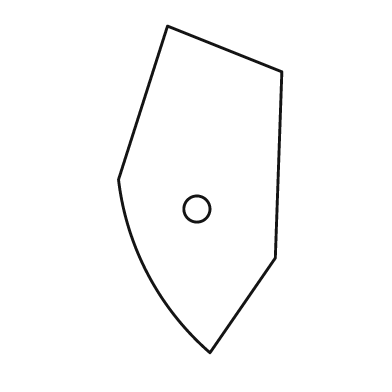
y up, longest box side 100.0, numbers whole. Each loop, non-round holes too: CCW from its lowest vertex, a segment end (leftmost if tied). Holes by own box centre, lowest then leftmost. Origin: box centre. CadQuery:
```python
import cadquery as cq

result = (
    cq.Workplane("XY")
    .moveTo(3.0, -50.0)
    .lineTo(23.0, -21.0)
    .lineTo(25.0, 36.0)
    .lineTo(-10.0, 50.0)
    .lineTo(-25.0, 3.0)
    .threePointArc((-16.0, -26.0), (3.0, -50.0))
    .close()
    .moveTo(-1.0, -6.0)
    .circle(4.0)
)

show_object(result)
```